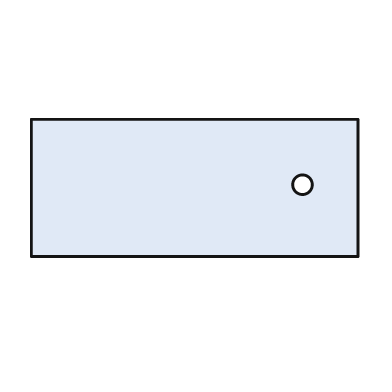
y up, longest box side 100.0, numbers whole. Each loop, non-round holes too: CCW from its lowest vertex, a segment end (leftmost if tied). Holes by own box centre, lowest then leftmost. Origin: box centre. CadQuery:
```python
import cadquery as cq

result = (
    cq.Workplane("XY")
    .moveTo(-50.0, -21.0)
    .lineTo(50.0, -21.0)
    .lineTo(50.0, 21.0)
    .lineTo(-50.0, 21.0)
    .close()
    .moveTo(33.0, 1.0)
    .circle(3.0)
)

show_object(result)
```